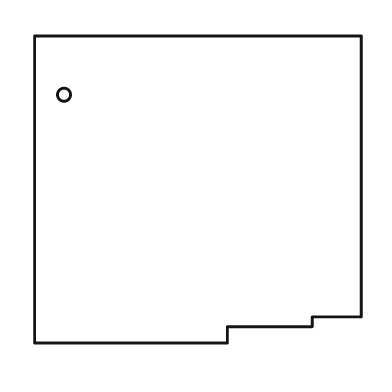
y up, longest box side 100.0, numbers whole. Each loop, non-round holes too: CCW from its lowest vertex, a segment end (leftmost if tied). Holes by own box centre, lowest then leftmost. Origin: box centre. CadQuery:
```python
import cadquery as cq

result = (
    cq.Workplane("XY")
    .moveTo(-50.0, -47.0)
    .lineTo(9.0, -47.0)
    .lineTo(9.0, -42.0)
    .lineTo(35.0, -42.0)
    .lineTo(35.0, -39.0)
    .lineTo(50.0, -39.0)
    .lineTo(50.0, 47.0)
    .lineTo(-50.0, 47.0)
    .close()
    .moveTo(-41.0, 29.0)
    .circle(2.0)
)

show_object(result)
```